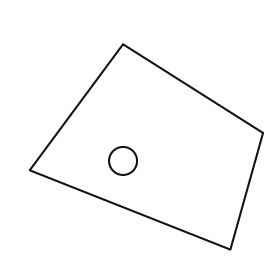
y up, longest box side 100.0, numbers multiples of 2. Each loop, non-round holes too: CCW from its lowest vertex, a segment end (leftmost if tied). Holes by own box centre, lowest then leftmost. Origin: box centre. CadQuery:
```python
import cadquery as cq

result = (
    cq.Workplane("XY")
    .moveTo(36.0, -44.0)
    .lineTo(50.0, 6.0)
    .lineTo(-10.0, 44.0)
    .lineTo(-50.0, -10.0)
    .close()
    .moveTo(-10.0, -6.0)
    .circle(6.0)
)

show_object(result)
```